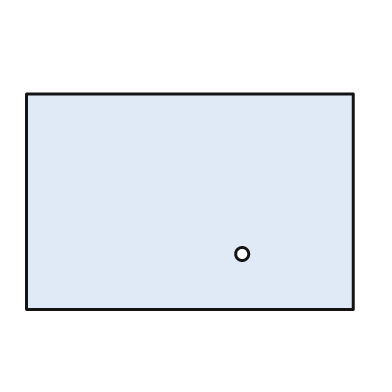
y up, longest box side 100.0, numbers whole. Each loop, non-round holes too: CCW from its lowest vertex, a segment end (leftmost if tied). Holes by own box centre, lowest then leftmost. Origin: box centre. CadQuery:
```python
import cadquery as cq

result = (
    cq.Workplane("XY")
    .moveTo(-50.0, -33.0)
    .lineTo(50.0, -33.0)
    .lineTo(50.0, 33.0)
    .lineTo(-50.0, 33.0)
    .close()
    .moveTo(16.0, -16.0)
    .circle(2.0)
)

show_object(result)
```